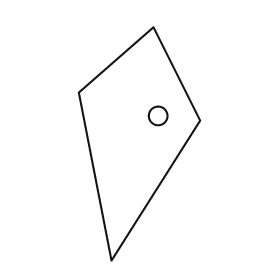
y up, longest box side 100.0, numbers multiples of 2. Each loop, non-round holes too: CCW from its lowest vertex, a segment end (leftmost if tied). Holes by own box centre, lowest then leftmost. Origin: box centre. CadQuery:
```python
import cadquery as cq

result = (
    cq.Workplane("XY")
    .moveTo(-12.0, -50.0)
    .lineTo(26.0, 10.0)
    .lineTo(6.0, 50.0)
    .lineTo(-26.0, 22.0)
    .close()
    .moveTo(8.0, 12.0)
    .circle(4.0)
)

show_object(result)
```